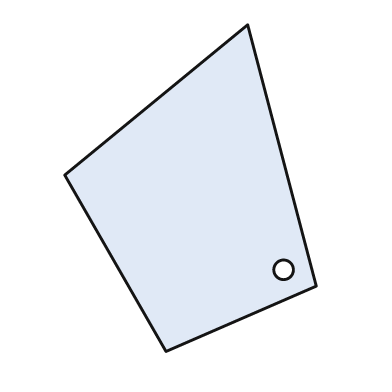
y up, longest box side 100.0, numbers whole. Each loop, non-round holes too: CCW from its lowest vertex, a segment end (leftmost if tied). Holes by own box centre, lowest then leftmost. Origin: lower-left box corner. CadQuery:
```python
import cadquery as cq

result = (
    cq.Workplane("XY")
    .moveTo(31.0, 0.0)
    .lineTo(77.0, 20.0)
    .lineTo(56.0, 100.0)
    .lineTo(0.0, 54.0)
    .close()
    .moveTo(67.0, 25.0)
    .circle(3.0)
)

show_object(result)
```